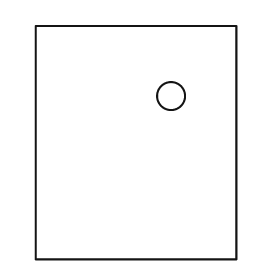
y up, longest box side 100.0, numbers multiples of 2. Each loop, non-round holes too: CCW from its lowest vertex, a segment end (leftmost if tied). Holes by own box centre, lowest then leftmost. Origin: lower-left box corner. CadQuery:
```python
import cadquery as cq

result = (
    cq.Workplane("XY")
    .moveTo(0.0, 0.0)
    .lineTo(86.0, 0.0)
    .lineTo(86.0, 100.0)
    .lineTo(0.0, 100.0)
    .close()
    .moveTo(58.0, 70.0)
    .circle(6.0)
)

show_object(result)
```